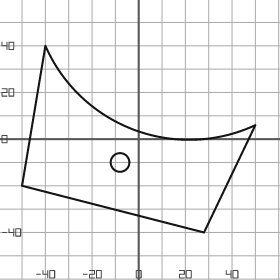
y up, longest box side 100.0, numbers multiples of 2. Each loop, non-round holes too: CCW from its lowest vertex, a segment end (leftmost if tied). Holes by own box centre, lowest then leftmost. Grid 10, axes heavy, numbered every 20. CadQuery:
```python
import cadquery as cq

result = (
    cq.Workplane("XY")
    .moveTo(28.0, -40.0)
    .lineTo(50.0, 6.0)
    .threePointArc((-2.0, 4.0), (-40.0, 40.0))
    .lineTo(-50.0, -20.0)
    .close()
    .moveTo(-8.0, -10.0)
    .circle(4.0)
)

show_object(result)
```